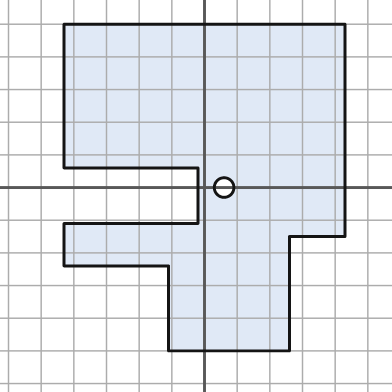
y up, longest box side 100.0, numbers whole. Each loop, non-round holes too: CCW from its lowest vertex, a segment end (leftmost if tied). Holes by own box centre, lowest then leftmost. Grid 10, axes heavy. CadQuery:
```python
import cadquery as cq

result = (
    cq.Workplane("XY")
    .moveTo(-11.0, -50.0)
    .lineTo(26.0, -50.0)
    .lineTo(26.0, -15.0)
    .lineTo(43.0, -15.0)
    .lineTo(43.0, 50.0)
    .lineTo(-43.0, 50.0)
    .lineTo(-43.0, 6.0)
    .lineTo(-2.0, 6.0)
    .lineTo(-2.0, -11.0)
    .lineTo(-43.0, -11.0)
    .lineTo(-43.0, -24.0)
    .lineTo(-11.0, -24.0)
    .close()
    .moveTo(6.0, 0.0)
    .circle(3.0)
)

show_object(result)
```